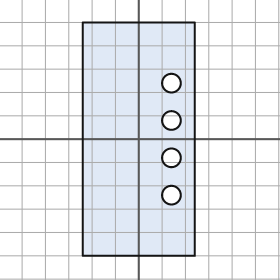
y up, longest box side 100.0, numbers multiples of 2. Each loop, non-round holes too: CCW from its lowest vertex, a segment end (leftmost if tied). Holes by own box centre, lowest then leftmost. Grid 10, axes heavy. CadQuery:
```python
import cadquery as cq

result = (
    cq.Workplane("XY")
    .moveTo(-24.0, -50.0)
    .lineTo(24.0, -50.0)
    .lineTo(24.0, 50.0)
    .lineTo(-24.0, 50.0)
    .close()
    .moveTo(14.0, -24.0)
    .circle(4.0)
    .moveTo(14.0, -8.0)
    .circle(4.0)
    .moveTo(14.0, 8.0)
    .circle(4.0)
    .moveTo(14.0, 24.0)
    .circle(4.0)
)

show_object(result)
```